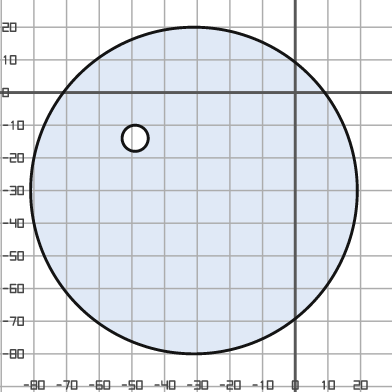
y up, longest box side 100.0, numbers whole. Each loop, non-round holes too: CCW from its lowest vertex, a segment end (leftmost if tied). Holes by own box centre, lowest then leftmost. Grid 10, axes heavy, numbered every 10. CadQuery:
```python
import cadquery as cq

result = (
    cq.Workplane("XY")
    .moveTo(-31.0, -30.0)
    .circle(50.0)
    .moveTo(-49.0, -14.0)
    .circle(4.0)
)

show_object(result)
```